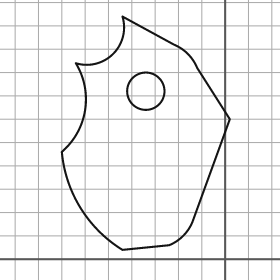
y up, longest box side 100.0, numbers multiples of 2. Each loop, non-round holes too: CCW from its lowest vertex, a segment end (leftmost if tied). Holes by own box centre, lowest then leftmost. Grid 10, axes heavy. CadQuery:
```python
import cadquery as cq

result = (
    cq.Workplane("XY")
    .moveTo(-44.0, 4.0)
    .lineTo(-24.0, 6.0)
    .threePointArc((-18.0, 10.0), (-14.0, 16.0))
    .lineTo(2.0, 60.0)
    .lineTo(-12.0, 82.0)
    .threePointArc((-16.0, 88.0), (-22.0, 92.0))
    .lineTo(-44.0, 104.0)
    .threePointArc((-48.0, 88.0), (-64.0, 84.0))
    .threePointArc((-60.0, 64.0), (-70.0, 46.0))
    .threePointArc((-62.0, 22.0), (-44.0, 4.0))
    .close()
    .moveTo(-34.0, 72.0)
    .circle(8.0)
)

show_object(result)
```